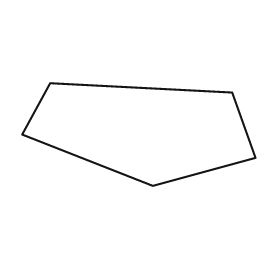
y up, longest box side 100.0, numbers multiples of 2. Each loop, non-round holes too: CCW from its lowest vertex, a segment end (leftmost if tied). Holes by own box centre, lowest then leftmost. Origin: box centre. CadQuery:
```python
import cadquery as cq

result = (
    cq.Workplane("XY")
    .moveTo(6.0, -22.0)
    .lineTo(50.0, -10.0)
    .lineTo(40.0, 18.0)
    .lineTo(-38.0, 22.0)
    .lineTo(-50.0, 0.0)
    .close()
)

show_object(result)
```